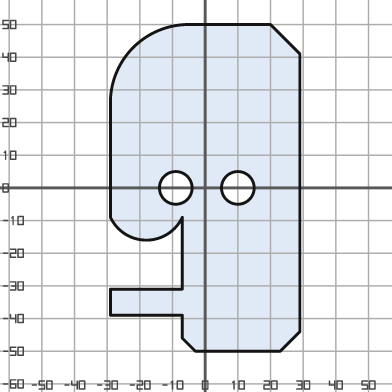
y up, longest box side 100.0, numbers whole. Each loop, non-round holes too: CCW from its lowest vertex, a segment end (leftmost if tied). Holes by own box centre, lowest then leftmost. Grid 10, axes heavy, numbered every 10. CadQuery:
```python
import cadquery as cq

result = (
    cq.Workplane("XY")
    .moveTo(-3.0, -50.0)
    .lineTo(23.0, -50.0)
    .lineTo(29.0, -44.0)
    .lineTo(29.0, 41.0)
    .lineTo(20.0, 50.0)
    .lineTo(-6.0, 50.0)
    .threePointArc((-22.0, 43.0), (-29.0, 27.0))
    .lineTo(-29.0, -9.0)
    .threePointArc((-18.0, -16.0), (-7.0, -9.0))
    .lineTo(-7.0, -31.0)
    .lineTo(-29.0, -31.0)
    .lineTo(-29.0, -39.0)
    .lineTo(-7.0, -39.0)
    .lineTo(-7.0, -46.0)
    .close()
    .moveTo(-9.0, 0.0)
    .circle(5.0)
    .moveTo(10.0, 0.0)
    .circle(5.0)
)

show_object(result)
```